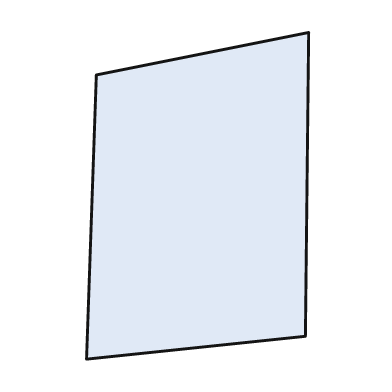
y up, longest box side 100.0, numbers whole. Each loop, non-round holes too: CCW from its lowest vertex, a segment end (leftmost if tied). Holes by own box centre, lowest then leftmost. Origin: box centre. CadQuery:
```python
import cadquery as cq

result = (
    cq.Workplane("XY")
    .moveTo(-34.0, -50.0)
    .lineTo(33.0, -43.0)
    .lineTo(34.0, 50.0)
    .lineTo(-31.0, 37.0)
    .close()
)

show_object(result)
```